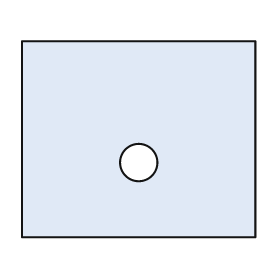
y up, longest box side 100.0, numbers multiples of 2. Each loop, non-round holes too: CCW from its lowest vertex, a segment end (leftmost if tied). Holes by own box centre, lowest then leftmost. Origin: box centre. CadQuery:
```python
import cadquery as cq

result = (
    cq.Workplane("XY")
    .moveTo(-50.0, -42.0)
    .lineTo(50.0, -42.0)
    .lineTo(50.0, 42.0)
    .lineTo(-50.0, 42.0)
    .close()
    .moveTo(0.0, -10.0)
    .circle(8.0)
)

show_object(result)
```